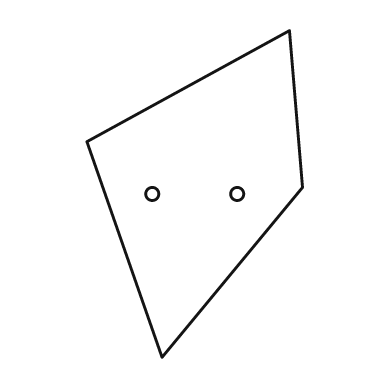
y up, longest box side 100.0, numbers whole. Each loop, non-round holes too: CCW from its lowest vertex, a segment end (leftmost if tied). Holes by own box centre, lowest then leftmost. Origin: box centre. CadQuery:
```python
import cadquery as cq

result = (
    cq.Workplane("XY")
    .moveTo(-10.0, -50.0)
    .lineTo(33.0, 2.0)
    .lineTo(29.0, 50.0)
    .lineTo(-33.0, 16.0)
    .close()
    .moveTo(-13.0, 0.0)
    .circle(2.0)
    .moveTo(13.0, 0.0)
    .circle(2.0)
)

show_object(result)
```